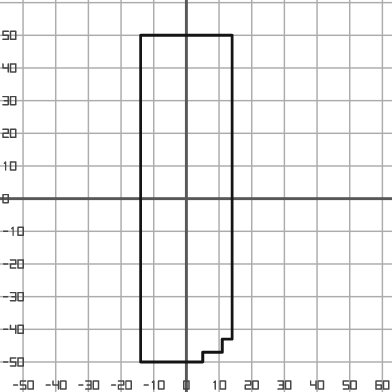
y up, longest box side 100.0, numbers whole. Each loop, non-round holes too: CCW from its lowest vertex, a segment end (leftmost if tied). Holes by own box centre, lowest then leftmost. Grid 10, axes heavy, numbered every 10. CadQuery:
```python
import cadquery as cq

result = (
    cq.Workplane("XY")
    .moveTo(-14.0, -50.0)
    .lineTo(5.0, -50.0)
    .lineTo(5.0, -47.0)
    .lineTo(11.0, -47.0)
    .lineTo(11.0, -43.0)
    .lineTo(14.0, -43.0)
    .lineTo(14.0, 50.0)
    .lineTo(-14.0, 50.0)
    .close()
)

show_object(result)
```